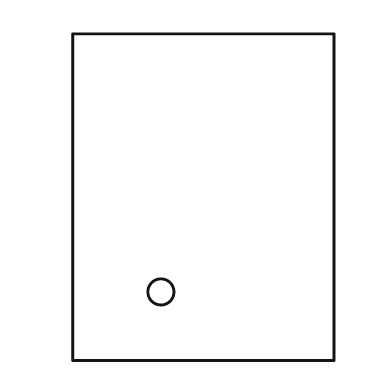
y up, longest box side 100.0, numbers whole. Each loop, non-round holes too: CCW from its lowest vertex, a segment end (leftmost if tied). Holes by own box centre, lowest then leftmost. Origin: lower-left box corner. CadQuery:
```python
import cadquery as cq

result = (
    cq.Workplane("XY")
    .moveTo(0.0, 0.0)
    .lineTo(80.0, 0.0)
    .lineTo(80.0, 100.0)
    .lineTo(0.0, 100.0)
    .close()
    .moveTo(27.0, 21.0)
    .circle(4.0)
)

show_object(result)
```